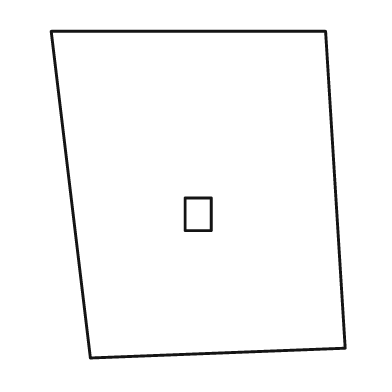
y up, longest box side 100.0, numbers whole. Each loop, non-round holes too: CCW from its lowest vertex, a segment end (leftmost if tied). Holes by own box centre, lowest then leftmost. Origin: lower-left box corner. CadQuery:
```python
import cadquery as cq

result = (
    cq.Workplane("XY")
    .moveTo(12.0, 0.0)
    .lineTo(90.0, 3.0)
    .lineTo(84.0, 100.0)
    .lineTo(0.0, 100.0)
    .close()
    .moveTo(41.0, 39.0)
    .lineTo(49.0, 39.0)
    .lineTo(49.0, 49.0)
    .lineTo(41.0, 49.0)
    .close()
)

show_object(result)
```